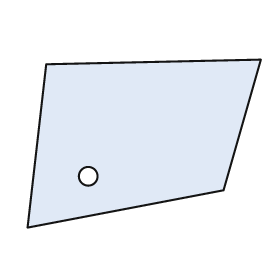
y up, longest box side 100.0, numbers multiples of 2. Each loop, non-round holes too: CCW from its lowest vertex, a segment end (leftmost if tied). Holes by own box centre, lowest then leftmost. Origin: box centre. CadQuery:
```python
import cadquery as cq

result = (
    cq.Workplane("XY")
    .moveTo(-50.0, -36.0)
    .lineTo(34.0, -20.0)
    .lineTo(50.0, 36.0)
    .lineTo(-42.0, 34.0)
    .close()
    .moveTo(-24.0, -14.0)
    .circle(4.0)
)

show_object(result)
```